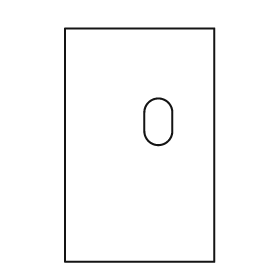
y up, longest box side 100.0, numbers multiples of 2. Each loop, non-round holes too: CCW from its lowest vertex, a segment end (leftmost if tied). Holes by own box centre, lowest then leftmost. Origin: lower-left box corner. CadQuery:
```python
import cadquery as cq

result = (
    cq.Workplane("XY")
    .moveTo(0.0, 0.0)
    .lineTo(64.0, 0.0)
    .lineTo(64.0, 100.0)
    .lineTo(0.0, 100.0)
    .close()
    .moveTo(34.0, 56.0)
    .threePointArc((40.0, 50.0), (46.0, 56.0))
    .lineTo(46.0, 64.0)
    .threePointArc((40.0, 70.0), (34.0, 64.0))
    .close()
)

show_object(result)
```